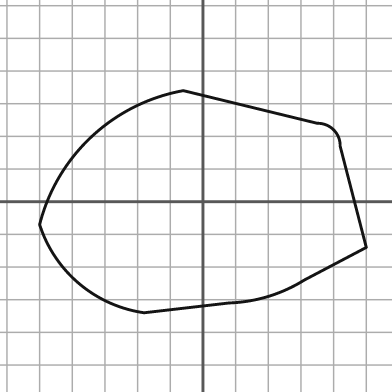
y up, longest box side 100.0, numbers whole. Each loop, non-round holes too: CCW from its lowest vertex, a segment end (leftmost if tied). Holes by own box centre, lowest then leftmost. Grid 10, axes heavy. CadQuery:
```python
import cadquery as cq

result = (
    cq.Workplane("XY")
    .moveTo(-18.0, -34.0)
    .lineTo(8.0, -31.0)
    .threePointArc((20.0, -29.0), (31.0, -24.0))
    .lineTo(50.0, -14.0)
    .lineTo(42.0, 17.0)
    .threePointArc((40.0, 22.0), (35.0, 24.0))
    .lineTo(-6.0, 34.0)
    .threePointArc((-34.0, 20.0), (-50.0, -7.0))
    .threePointArc((-38.0, -25.0), (-18.0, -34.0))
    .close()
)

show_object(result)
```